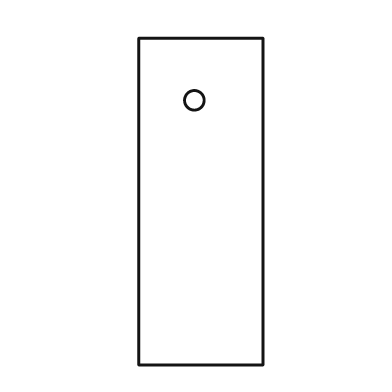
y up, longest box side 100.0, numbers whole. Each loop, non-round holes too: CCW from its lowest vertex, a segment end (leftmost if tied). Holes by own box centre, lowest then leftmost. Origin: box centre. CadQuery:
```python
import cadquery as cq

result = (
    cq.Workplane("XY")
    .moveTo(-19.0, -50.0)
    .lineTo(19.0, -50.0)
    .lineTo(19.0, 50.0)
    .lineTo(-19.0, 50.0)
    .close()
    .moveTo(-2.0, 31.0)
    .circle(3.0)
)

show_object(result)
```